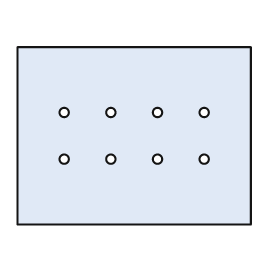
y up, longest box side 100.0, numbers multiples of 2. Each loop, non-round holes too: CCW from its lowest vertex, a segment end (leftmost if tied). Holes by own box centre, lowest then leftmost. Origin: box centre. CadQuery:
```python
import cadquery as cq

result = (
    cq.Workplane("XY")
    .moveTo(-50.0, -38.0)
    .lineTo(50.0, -38.0)
    .lineTo(50.0, 38.0)
    .lineTo(-50.0, 38.0)
    .close()
    .moveTo(-30.0, -10.0)
    .circle(2.0)
    .moveTo(-10.0, -10.0)
    .circle(2.0)
    .moveTo(10.0, -10.0)
    .circle(2.0)
    .moveTo(30.0, -10.0)
    .circle(2.0)
    .moveTo(-30.0, 10.0)
    .circle(2.0)
    .moveTo(-10.0, 10.0)
    .circle(2.0)
    .moveTo(10.0, 10.0)
    .circle(2.0)
    .moveTo(30.0, 10.0)
    .circle(2.0)
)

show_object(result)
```